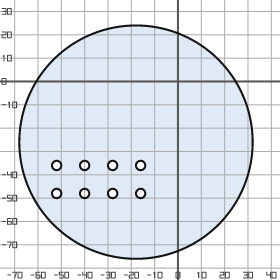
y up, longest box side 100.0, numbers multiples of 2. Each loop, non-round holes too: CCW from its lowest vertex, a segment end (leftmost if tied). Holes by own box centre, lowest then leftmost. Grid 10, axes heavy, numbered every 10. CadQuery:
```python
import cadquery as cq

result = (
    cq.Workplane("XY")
    .moveTo(-18.0, -26.0)
    .circle(50.0)
    .moveTo(-52.0, -48.0)
    .circle(2.0)
    .moveTo(-40.0, -48.0)
    .circle(2.0)
    .moveTo(-28.0, -48.0)
    .circle(2.0)
    .moveTo(-16.0, -48.0)
    .circle(2.0)
    .moveTo(-52.0, -36.0)
    .circle(2.0)
    .moveTo(-40.0, -36.0)
    .circle(2.0)
    .moveTo(-28.0, -36.0)
    .circle(2.0)
    .moveTo(-16.0, -36.0)
    .circle(2.0)
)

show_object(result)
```